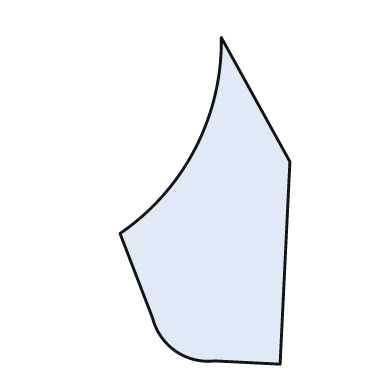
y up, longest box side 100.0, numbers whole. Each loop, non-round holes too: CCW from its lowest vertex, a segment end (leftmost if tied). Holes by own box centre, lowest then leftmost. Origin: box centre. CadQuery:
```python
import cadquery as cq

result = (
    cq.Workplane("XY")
    .moveTo(23.0, -50.0)
    .lineTo(26.0, 12.0)
    .lineTo(5.0, 50.0)
    .threePointArc((-3.0, 16.0), (-26.0, -10.0))
    .lineTo(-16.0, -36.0)
    .threePointArc((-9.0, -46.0), (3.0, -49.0))
    .close()
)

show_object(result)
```